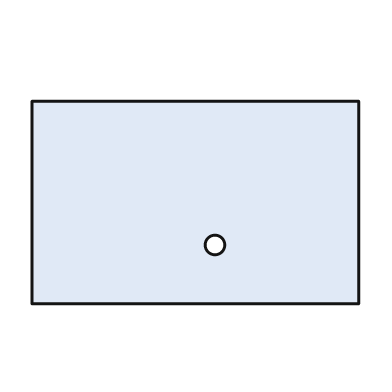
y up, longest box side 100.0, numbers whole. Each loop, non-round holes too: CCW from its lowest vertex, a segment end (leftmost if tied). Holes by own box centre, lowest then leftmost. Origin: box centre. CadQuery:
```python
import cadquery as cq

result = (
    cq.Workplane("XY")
    .moveTo(-50.0, -31.0)
    .lineTo(50.0, -31.0)
    .lineTo(50.0, 31.0)
    .lineTo(-50.0, 31.0)
    .close()
    .moveTo(6.0, -13.0)
    .circle(3.0)
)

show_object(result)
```